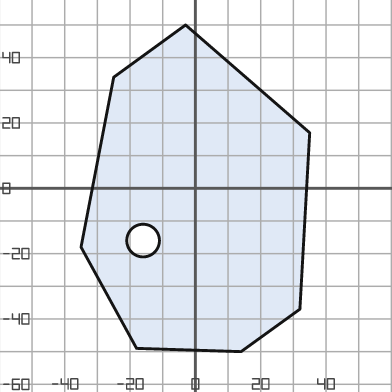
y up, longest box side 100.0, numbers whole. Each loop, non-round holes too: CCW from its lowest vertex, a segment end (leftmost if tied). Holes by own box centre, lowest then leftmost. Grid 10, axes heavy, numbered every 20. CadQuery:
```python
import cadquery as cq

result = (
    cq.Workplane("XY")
    .moveTo(14.0, -50.0)
    .lineTo(32.0, -37.0)
    .lineTo(35.0, 17.0)
    .lineTo(-3.0, 50.0)
    .lineTo(-25.0, 34.0)
    .lineTo(-35.0, -18.0)
    .lineTo(-18.0, -49.0)
    .close()
    .moveTo(-16.0, -16.0)
    .circle(5.0)
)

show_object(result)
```